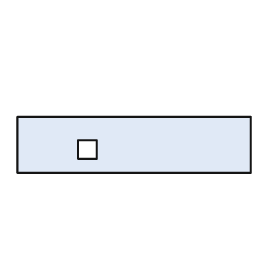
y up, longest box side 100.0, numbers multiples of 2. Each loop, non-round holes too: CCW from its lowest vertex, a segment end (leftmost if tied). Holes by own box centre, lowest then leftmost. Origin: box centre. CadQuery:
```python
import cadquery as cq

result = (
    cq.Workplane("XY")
    .moveTo(-50.0, -12.0)
    .lineTo(50.0, -12.0)
    .lineTo(50.0, 12.0)
    .lineTo(-50.0, 12.0)
    .close()
    .moveTo(-24.0, -6.0)
    .lineTo(-16.0, -6.0)
    .lineTo(-16.0, 2.0)
    .lineTo(-24.0, 2.0)
    .close()
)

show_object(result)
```